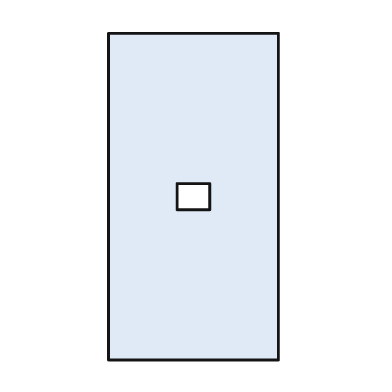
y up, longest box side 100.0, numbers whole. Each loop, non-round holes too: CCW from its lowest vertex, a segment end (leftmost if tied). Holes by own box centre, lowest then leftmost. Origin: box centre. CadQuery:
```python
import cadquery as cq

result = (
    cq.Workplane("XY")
    .moveTo(-26.0, -50.0)
    .lineTo(26.0, -50.0)
    .lineTo(26.0, 50.0)
    .lineTo(-26.0, 50.0)
    .close()
    .moveTo(-5.0, -4.0)
    .lineTo(5.0, -4.0)
    .lineTo(5.0, 4.0)
    .lineTo(-5.0, 4.0)
    .close()
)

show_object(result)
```